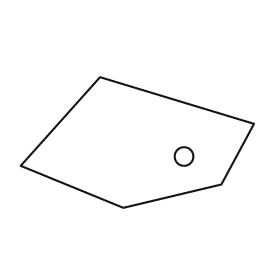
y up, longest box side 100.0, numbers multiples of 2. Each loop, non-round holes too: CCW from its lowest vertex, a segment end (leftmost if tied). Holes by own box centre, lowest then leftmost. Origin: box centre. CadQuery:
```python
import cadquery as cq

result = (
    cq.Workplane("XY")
    .moveTo(-6.0, -28.0)
    .lineTo(36.0, -18.0)
    .lineTo(50.0, 8.0)
    .lineTo(-16.0, 28.0)
    .lineTo(-50.0, -10.0)
    .close()
    .moveTo(20.0, -6.0)
    .circle(4.0)
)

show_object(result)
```